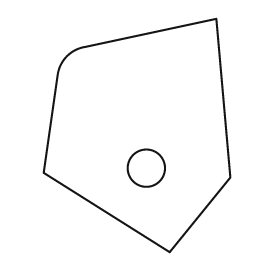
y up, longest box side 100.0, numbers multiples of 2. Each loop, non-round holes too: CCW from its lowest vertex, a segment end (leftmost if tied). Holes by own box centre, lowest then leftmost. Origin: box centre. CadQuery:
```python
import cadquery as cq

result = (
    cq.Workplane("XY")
    .moveTo(14.0, -50.0)
    .lineTo(40.0, -18.0)
    .lineTo(34.0, 50.0)
    .lineTo(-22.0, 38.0)
    .threePointArc((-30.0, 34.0), (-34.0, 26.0))
    .lineTo(-40.0, -16.0)
    .close()
    .moveTo(4.0, -14.0)
    .circle(8.0)
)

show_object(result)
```